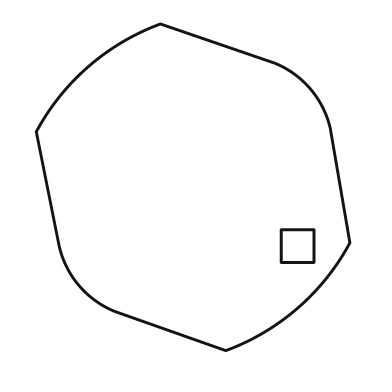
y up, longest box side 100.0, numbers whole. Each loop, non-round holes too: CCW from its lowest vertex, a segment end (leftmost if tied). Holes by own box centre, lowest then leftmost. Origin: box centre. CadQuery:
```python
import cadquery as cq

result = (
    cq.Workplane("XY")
    .moveTo(10.0, -50.0)
    .threePointArc((32.0, -37.0), (48.0, -17.0))
    .lineTo(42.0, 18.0)
    .threePointArc((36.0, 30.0), (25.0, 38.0))
    .lineTo(-10.0, 50.0)
    .threePointArc((-32.0, 37.0), (-48.0, 17.0))
    .lineTo(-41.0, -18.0)
    .threePointArc((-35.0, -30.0), (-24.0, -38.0))
    .close()
    .moveTo(27.0, -23.0)
    .lineTo(37.0, -23.0)
    .lineTo(37.0, -13.0)
    .lineTo(27.0, -13.0)
    .close()
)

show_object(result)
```